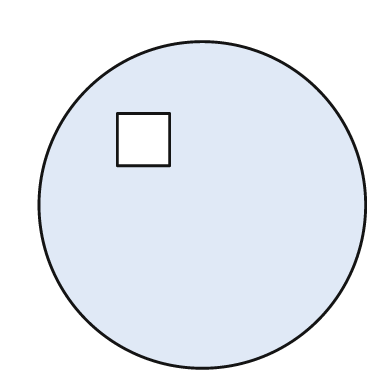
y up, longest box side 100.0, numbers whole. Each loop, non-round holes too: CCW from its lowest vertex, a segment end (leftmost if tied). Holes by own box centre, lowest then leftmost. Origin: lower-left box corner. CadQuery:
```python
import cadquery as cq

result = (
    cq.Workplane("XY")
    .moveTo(50.0, 50.0)
    .circle(50.0)
    .moveTo(24.0, 62.0)
    .lineTo(40.0, 62.0)
    .lineTo(40.0, 78.0)
    .lineTo(24.0, 78.0)
    .close()
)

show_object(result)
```